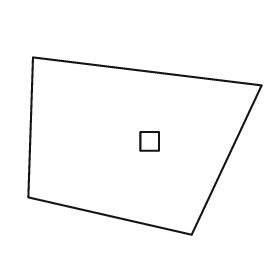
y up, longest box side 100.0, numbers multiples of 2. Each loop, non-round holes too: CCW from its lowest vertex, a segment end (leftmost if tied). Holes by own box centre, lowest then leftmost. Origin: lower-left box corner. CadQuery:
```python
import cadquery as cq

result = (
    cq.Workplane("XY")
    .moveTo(70.0, 0.0)
    .lineTo(100.0, 64.0)
    .lineTo(2.0, 76.0)
    .lineTo(0.0, 16.0)
    .close()
    .moveTo(48.0, 36.0)
    .lineTo(56.0, 36.0)
    .lineTo(56.0, 44.0)
    .lineTo(48.0, 44.0)
    .close()
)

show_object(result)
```